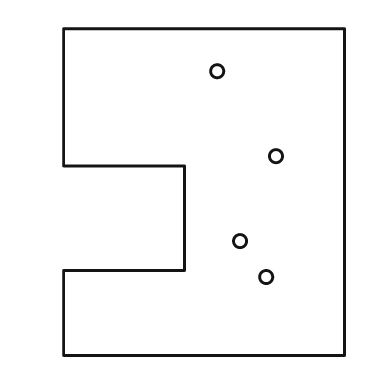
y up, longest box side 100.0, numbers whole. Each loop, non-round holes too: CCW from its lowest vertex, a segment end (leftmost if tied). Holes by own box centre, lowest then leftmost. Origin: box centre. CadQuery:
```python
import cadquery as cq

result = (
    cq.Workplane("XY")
    .moveTo(-43.0, -50.0)
    .lineTo(43.0, -50.0)
    .lineTo(43.0, 50.0)
    .lineTo(-43.0, 50.0)
    .lineTo(-43.0, 8.0)
    .lineTo(-6.0, 8.0)
    .lineTo(-6.0, -24.0)
    .lineTo(-43.0, -24.0)
    .close()
    .moveTo(19.0, -26.0)
    .circle(2.0)
    .moveTo(11.0, -15.0)
    .circle(2.0)
    .moveTo(22.0, 11.0)
    .circle(2.0)
    .moveTo(4.0, 37.0)
    .circle(2.0)
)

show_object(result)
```